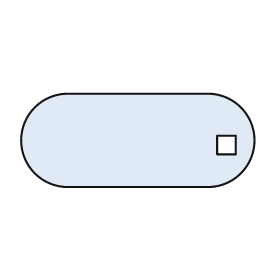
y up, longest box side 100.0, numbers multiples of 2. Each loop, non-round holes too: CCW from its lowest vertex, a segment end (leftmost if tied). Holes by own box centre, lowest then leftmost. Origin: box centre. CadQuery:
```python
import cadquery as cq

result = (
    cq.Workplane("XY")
    .moveTo(-30.0, -20.0)
    .lineTo(30.0, -20.0)
    .threePointArc((50.0, 0.0), (30.0, 20.0))
    .lineTo(-30.0, 20.0)
    .threePointArc((-50.0, 0.0), (-30.0, -20.0))
    .close()
    .moveTo(34.0, -6.0)
    .lineTo(42.0, -6.0)
    .lineTo(42.0, 2.0)
    .lineTo(34.0, 2.0)
    .close()
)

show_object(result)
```